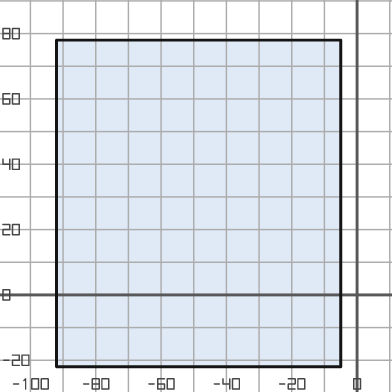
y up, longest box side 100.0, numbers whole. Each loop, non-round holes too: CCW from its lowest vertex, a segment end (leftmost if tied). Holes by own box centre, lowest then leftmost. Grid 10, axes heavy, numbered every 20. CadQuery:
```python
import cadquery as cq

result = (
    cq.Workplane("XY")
    .moveTo(-92.0, -22.0)
    .lineTo(-5.0, -22.0)
    .lineTo(-5.0, 78.0)
    .lineTo(-92.0, 78.0)
    .close()
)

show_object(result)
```